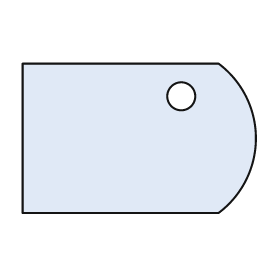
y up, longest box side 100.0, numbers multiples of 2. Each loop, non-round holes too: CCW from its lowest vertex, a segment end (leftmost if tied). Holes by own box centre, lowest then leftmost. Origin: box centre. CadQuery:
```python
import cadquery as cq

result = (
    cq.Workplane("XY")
    .moveTo(-50.0, -32.0)
    .lineTo(34.0, -32.0)
    .threePointArc((50.0, 0.0), (34.0, 32.0))
    .lineTo(-50.0, 32.0)
    .close()
    .moveTo(18.0, 18.0)
    .circle(6.0)
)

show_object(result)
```